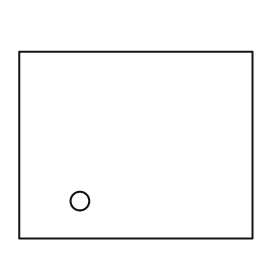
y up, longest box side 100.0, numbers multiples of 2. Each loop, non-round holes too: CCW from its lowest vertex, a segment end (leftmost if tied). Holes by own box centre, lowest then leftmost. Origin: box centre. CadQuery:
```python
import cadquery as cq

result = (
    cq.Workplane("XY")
    .moveTo(-50.0, -40.0)
    .lineTo(50.0, -40.0)
    .lineTo(50.0, 40.0)
    .lineTo(-50.0, 40.0)
    .close()
    .moveTo(-24.0, -24.0)
    .circle(4.0)
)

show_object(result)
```